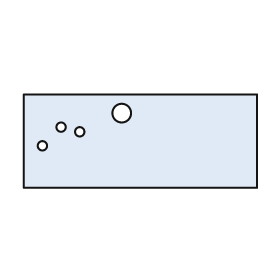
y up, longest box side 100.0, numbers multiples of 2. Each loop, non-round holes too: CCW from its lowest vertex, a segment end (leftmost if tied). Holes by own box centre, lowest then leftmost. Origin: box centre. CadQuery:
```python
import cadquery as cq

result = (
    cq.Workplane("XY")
    .moveTo(-50.0, -20.0)
    .lineTo(50.0, -20.0)
    .lineTo(50.0, 20.0)
    .lineTo(-50.0, 20.0)
    .close()
    .moveTo(-42.0, -2.0)
    .circle(2.0)
    .moveTo(-26.0, 4.0)
    .circle(2.0)
    .moveTo(-34.0, 6.0)
    .circle(2.0)
    .moveTo(-8.0, 12.0)
    .circle(4.0)
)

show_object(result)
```